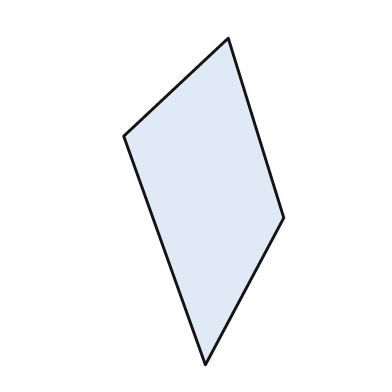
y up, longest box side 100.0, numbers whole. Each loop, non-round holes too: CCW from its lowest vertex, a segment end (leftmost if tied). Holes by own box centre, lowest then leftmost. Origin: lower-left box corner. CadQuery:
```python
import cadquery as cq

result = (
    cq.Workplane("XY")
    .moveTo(25.0, 0.0)
    .lineTo(49.0, 45.0)
    .lineTo(32.0, 100.0)
    .lineTo(0.0, 70.0)
    .close()
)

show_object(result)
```